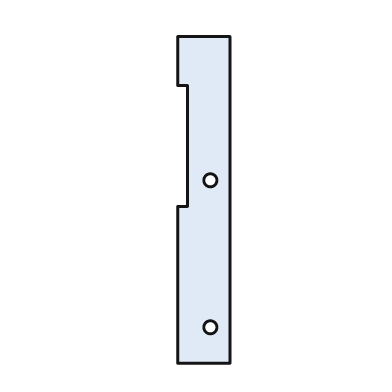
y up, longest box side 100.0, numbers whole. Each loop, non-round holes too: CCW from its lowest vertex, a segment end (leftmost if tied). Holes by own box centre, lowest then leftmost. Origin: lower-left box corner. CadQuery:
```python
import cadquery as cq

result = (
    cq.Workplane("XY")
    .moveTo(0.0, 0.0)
    .lineTo(16.0, 0.0)
    .lineTo(16.0, 100.0)
    .lineTo(0.0, 100.0)
    .lineTo(0.0, 85.0)
    .lineTo(3.0, 85.0)
    .lineTo(3.0, 48.0)
    .lineTo(0.0, 48.0)
    .close()
    .moveTo(10.0, 11.0)
    .circle(2.0)
    .moveTo(10.0, 56.0)
    .circle(2.0)
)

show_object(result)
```